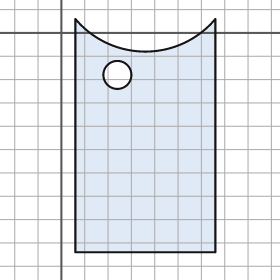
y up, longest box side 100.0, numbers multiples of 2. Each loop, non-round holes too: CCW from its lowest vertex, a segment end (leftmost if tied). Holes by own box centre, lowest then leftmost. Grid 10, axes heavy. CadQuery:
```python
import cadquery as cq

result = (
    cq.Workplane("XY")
    .moveTo(6.0, -94.0)
    .lineTo(66.0, -94.0)
    .lineTo(66.0, 6.0)
    .threePointArc((36.0, -8.0), (6.0, 6.0))
    .close()
    .moveTo(24.0, -18.0)
    .circle(6.0)
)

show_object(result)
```